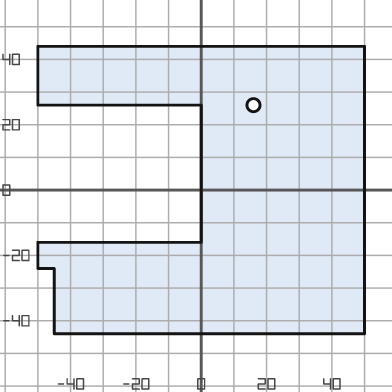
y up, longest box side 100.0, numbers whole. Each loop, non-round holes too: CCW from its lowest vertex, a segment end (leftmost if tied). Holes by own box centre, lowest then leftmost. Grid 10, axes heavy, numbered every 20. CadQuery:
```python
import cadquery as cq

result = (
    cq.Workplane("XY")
    .moveTo(-45.0, -44.0)
    .lineTo(50.0, -44.0)
    .lineTo(50.0, 44.0)
    .lineTo(-50.0, 44.0)
    .lineTo(-50.0, 26.0)
    .lineTo(0.0, 26.0)
    .lineTo(0.0, -16.0)
    .lineTo(-50.0, -16.0)
    .lineTo(-50.0, -24.0)
    .lineTo(-45.0, -24.0)
    .close()
    .moveTo(16.0, 26.0)
    .circle(2.0)
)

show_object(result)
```